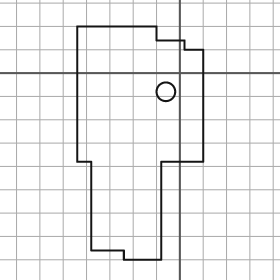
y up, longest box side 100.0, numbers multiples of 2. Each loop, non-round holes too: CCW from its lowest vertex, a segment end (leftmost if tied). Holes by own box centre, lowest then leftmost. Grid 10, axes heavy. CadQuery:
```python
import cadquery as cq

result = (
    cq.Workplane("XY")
    .moveTo(-24.0, -80.0)
    .lineTo(-8.0, -80.0)
    .lineTo(-8.0, -38.0)
    .lineTo(10.0, -38.0)
    .lineTo(10.0, 10.0)
    .lineTo(2.0, 10.0)
    .lineTo(2.0, 14.0)
    .lineTo(-10.0, 14.0)
    .lineTo(-10.0, 20.0)
    .lineTo(-44.0, 20.0)
    .lineTo(-44.0, -38.0)
    .lineTo(-38.0, -38.0)
    .lineTo(-38.0, -76.0)
    .lineTo(-24.0, -76.0)
    .close()
    .moveTo(-6.0, -8.0)
    .circle(4.0)
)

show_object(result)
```